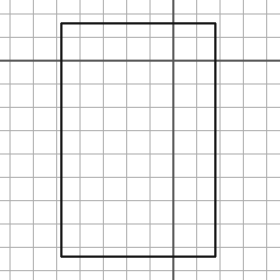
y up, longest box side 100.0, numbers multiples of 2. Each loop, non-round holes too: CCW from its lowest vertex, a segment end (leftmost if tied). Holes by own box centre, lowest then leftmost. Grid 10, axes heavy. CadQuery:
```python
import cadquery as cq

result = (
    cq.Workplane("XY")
    .moveTo(-48.0, -84.0)
    .lineTo(18.0, -84.0)
    .lineTo(18.0, 16.0)
    .lineTo(-48.0, 16.0)
    .close()
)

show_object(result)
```